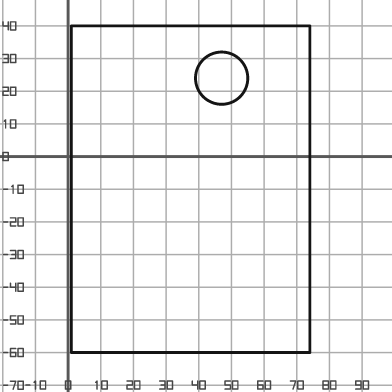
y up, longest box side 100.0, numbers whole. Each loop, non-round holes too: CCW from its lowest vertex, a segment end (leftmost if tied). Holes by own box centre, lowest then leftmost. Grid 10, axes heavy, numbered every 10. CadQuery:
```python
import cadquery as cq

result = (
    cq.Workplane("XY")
    .moveTo(1.0, -60.0)
    .lineTo(74.0, -60.0)
    .lineTo(74.0, 40.0)
    .lineTo(1.0, 40.0)
    .close()
    .moveTo(47.0, 24.0)
    .circle(8.0)
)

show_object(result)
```